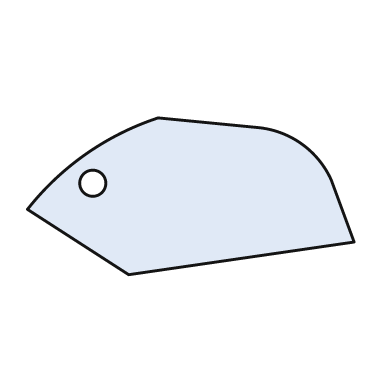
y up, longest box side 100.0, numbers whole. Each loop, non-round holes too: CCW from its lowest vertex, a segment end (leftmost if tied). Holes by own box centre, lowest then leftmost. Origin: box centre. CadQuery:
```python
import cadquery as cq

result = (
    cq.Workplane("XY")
    .moveTo(-19.0, -24.0)
    .lineTo(50.0, -14.0)
    .lineTo(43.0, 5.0)
    .threePointArc((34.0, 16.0), (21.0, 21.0))
    .lineTo(-10.0, 24.0)
    .threePointArc((-32.0, 13.0), (-50.0, -4.0))
    .close()
    .moveTo(-30.0, 4.0)
    .circle(4.0)
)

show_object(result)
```